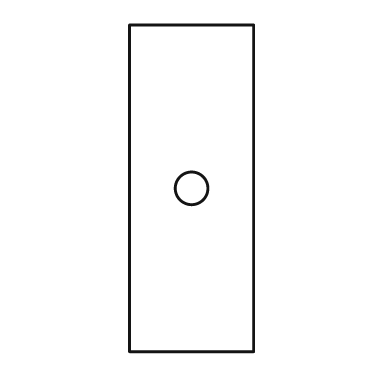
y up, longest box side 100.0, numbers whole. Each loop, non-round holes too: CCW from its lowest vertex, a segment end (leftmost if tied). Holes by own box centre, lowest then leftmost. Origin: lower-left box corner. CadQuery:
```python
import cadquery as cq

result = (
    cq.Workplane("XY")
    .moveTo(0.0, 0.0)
    .lineTo(38.0, 0.0)
    .lineTo(38.0, 100.0)
    .lineTo(0.0, 100.0)
    .close()
    .moveTo(19.0, 50.0)
    .circle(5.0)
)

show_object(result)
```